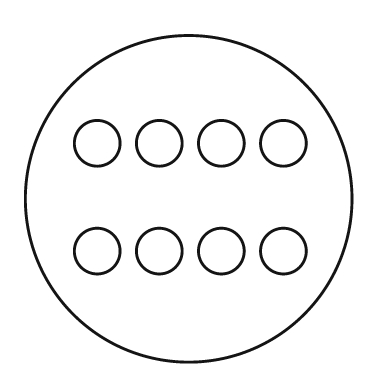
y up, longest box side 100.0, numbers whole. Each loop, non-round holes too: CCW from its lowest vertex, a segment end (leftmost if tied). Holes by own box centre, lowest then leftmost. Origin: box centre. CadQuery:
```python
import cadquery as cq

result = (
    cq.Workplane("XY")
    .moveTo(0.0, 0.0)
    .circle(50.0)
    .moveTo(-28.0, -16.0)
    .circle(7.0)
    .moveTo(-9.0, -16.0)
    .circle(7.0)
    .moveTo(10.0, -16.0)
    .circle(7.0)
    .moveTo(29.0, -16.0)
    .circle(7.0)
    .moveTo(-28.0, 17.0)
    .circle(7.0)
    .moveTo(-9.0, 17.0)
    .circle(7.0)
    .moveTo(10.0, 17.0)
    .circle(7.0)
    .moveTo(29.0, 17.0)
    .circle(7.0)
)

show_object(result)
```